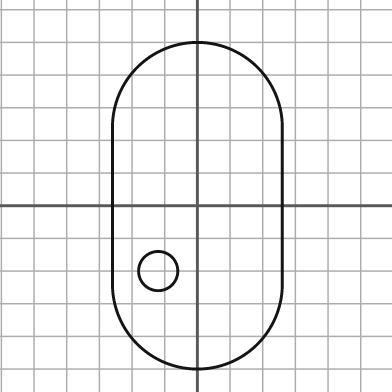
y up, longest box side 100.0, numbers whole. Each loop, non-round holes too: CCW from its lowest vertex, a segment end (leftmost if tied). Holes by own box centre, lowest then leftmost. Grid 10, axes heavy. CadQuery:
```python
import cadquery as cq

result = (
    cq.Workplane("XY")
    .moveTo(-26.0, -24.0)
    .threePointArc((0.0, -50.0), (26.0, -24.0))
    .lineTo(26.0, 24.0)
    .threePointArc((0.0, 50.0), (-26.0, 24.0))
    .close()
    .moveTo(-12.0, -20.0)
    .circle(6.0)
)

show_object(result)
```